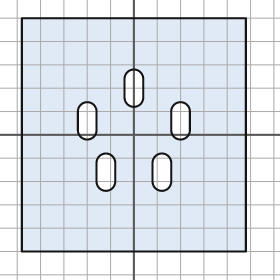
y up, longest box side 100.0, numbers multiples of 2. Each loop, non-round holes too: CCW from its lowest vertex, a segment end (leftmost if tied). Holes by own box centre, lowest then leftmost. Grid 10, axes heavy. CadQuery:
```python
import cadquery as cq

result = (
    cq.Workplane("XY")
    .moveTo(-48.0, -50.0)
    .lineTo(48.0, -50.0)
    .lineTo(48.0, 50.0)
    .lineTo(-48.0, 50.0)
    .close()
    .moveTo(-16.0, -20.0)
    .threePointArc((-12.0, -24.0), (-8.0, -20.0))
    .lineTo(-8.0, -12.0)
    .threePointArc((-12.0, -8.0), (-16.0, -12.0))
    .close()
    .moveTo(8.0, -20.0)
    .threePointArc((12.0, -24.0), (16.0, -20.0))
    .lineTo(16.0, -12.0)
    .threePointArc((12.0, -8.0), (8.0, -12.0))
    .close()
    .moveTo(-24.0, 2.0)
    .threePointArc((-20.0, -2.0), (-16.0, 2.0))
    .lineTo(-16.0, 10.0)
    .threePointArc((-20.0, 14.0), (-24.0, 10.0))
    .close()
    .moveTo(16.0, 2.0)
    .threePointArc((20.0, -2.0), (24.0, 2.0))
    .lineTo(24.0, 10.0)
    .threePointArc((20.0, 14.0), (16.0, 10.0))
    .close()
    .moveTo(-4.0, 16.0)
    .threePointArc((0.0, 12.0), (4.0, 16.0))
    .lineTo(4.0, 24.0)
    .threePointArc((0.0, 28.0), (-4.0, 24.0))
    .close()
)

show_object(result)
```